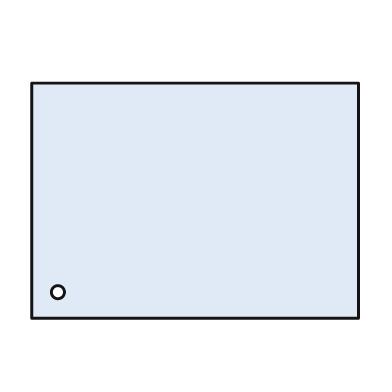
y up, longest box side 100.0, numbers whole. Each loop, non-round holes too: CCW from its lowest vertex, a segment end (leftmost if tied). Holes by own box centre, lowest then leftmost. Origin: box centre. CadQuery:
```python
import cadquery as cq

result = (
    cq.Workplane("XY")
    .moveTo(-50.0, -36.0)
    .lineTo(50.0, -36.0)
    .lineTo(50.0, 36.0)
    .lineTo(-50.0, 36.0)
    .close()
    .moveTo(-42.0, -28.0)
    .circle(2.0)
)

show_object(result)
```